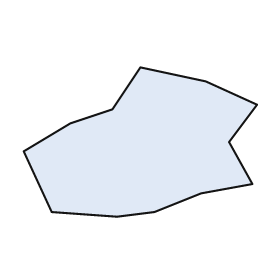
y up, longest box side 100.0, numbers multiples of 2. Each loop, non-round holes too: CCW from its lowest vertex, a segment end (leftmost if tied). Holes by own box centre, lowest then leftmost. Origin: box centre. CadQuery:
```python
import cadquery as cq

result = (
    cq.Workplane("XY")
    .moveTo(-10.0, -32.0)
    .lineTo(6.0, -30.0)
    .lineTo(26.0, -22.0)
    .lineTo(48.0, -18.0)
    .lineTo(38.0, 0.0)
    .lineTo(50.0, 16.0)
    .lineTo(28.0, 26.0)
    .lineTo(0.0, 32.0)
    .lineTo(-12.0, 14.0)
    .lineTo(-30.0, 8.0)
    .lineTo(-50.0, -4.0)
    .lineTo(-38.0, -30.0)
    .close()
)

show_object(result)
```